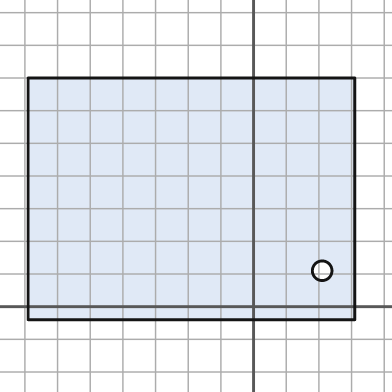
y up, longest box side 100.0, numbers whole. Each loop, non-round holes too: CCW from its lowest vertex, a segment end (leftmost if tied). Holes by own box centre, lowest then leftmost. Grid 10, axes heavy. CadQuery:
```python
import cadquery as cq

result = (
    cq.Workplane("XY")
    .moveTo(-69.0, -4.0)
    .lineTo(31.0, -4.0)
    .lineTo(31.0, 70.0)
    .lineTo(-69.0, 70.0)
    .close()
    .moveTo(21.0, 11.0)
    .circle(3.0)
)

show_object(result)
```